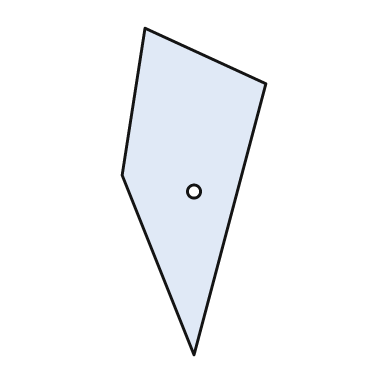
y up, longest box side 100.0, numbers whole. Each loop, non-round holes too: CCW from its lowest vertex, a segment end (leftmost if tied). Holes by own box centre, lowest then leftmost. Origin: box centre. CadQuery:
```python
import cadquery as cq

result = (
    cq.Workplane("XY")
    .moveTo(0.0, -50.0)
    .lineTo(22.0, 33.0)
    .lineTo(-15.0, 50.0)
    .lineTo(-22.0, 5.0)
    .close()
    .moveTo(0.0, 0.0)
    .circle(2.0)
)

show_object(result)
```